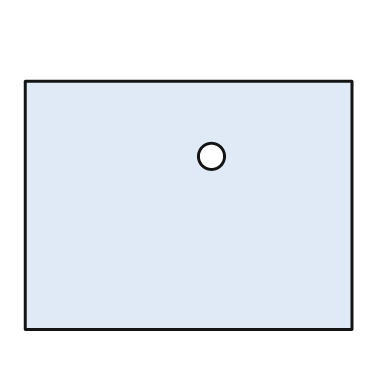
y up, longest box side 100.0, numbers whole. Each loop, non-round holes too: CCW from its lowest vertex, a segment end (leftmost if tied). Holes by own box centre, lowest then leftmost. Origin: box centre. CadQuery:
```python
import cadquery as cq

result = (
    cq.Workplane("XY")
    .moveTo(-50.0, -38.0)
    .lineTo(50.0, -38.0)
    .lineTo(50.0, 38.0)
    .lineTo(-50.0, 38.0)
    .close()
    .moveTo(7.0, 15.0)
    .circle(4.0)
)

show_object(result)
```